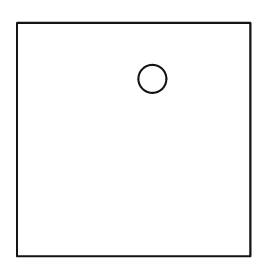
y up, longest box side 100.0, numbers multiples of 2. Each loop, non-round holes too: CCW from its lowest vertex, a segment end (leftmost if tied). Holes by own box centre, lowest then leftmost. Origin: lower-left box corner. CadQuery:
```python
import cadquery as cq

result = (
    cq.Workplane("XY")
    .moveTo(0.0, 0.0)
    .lineTo(100.0, 0.0)
    .lineTo(100.0, 100.0)
    .lineTo(0.0, 100.0)
    .close()
    .moveTo(58.0, 76.0)
    .circle(6.0)
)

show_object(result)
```